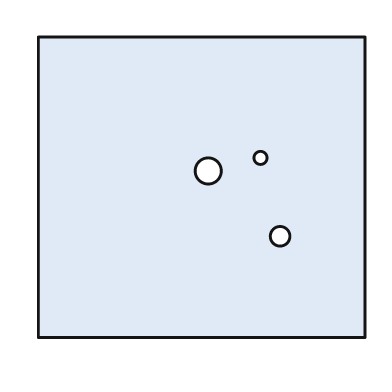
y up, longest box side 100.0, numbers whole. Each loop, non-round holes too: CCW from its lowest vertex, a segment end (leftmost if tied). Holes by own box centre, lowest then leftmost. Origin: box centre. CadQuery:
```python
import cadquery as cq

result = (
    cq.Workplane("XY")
    .moveTo(-50.0, -46.0)
    .lineTo(50.0, -46.0)
    .lineTo(50.0, 46.0)
    .lineTo(-50.0, 46.0)
    .close()
    .moveTo(24.0, -15.0)
    .circle(3.0)
    .moveTo(2.0, 5.0)
    .circle(4.0)
    .moveTo(18.0, 9.0)
    .circle(2.0)
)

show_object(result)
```